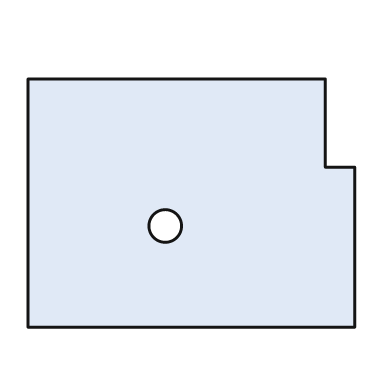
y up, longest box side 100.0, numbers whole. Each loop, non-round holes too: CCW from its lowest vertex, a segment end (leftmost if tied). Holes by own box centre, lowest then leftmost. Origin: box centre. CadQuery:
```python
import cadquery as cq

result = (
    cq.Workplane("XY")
    .moveTo(-50.0, -38.0)
    .lineTo(50.0, -38.0)
    .lineTo(50.0, 11.0)
    .lineTo(41.0, 11.0)
    .lineTo(41.0, 38.0)
    .lineTo(-50.0, 38.0)
    .close()
    .moveTo(-8.0, -7.0)
    .circle(5.0)
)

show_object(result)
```